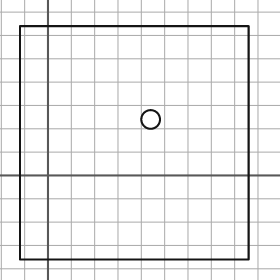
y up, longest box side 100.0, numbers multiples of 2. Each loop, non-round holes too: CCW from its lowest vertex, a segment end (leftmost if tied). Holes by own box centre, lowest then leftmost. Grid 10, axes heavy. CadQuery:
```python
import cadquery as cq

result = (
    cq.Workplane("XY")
    .moveTo(-12.0, -36.0)
    .lineTo(86.0, -36.0)
    .lineTo(86.0, 64.0)
    .lineTo(-12.0, 64.0)
    .close()
    .moveTo(44.0, 24.0)
    .circle(4.0)
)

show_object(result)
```